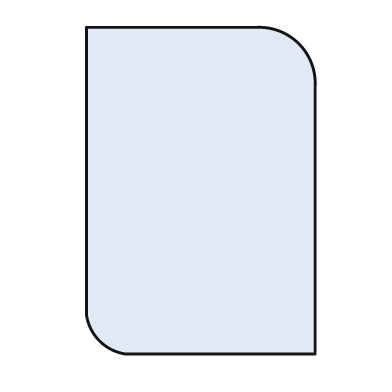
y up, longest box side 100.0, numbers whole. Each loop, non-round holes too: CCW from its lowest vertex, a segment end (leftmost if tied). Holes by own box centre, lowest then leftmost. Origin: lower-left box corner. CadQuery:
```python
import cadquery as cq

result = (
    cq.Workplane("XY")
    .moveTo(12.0, 0.0)
    .lineTo(70.0, 0.0)
    .lineTo(70.0, 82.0)
    .threePointArc((65.0, 95.0), (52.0, 100.0))
    .lineTo(0.0, 100.0)
    .lineTo(0.0, 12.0)
    .threePointArc((4.0, 4.0), (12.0, 0.0))
    .close()
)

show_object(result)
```